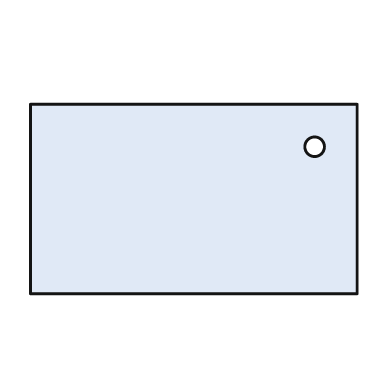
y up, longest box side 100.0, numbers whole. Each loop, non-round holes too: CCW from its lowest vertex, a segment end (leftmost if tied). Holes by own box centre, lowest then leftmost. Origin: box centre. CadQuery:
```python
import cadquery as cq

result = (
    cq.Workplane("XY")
    .moveTo(-50.0, -29.0)
    .lineTo(50.0, -29.0)
    .lineTo(50.0, 29.0)
    .lineTo(-50.0, 29.0)
    .close()
    .moveTo(37.0, 16.0)
    .circle(3.0)
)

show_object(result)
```